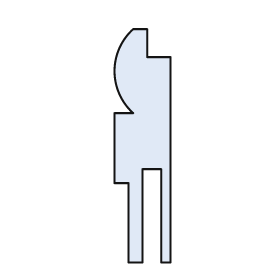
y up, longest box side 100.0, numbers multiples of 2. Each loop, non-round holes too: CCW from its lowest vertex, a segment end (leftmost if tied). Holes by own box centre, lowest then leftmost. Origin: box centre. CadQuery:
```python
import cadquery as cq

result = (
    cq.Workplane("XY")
    .moveTo(-6.0, -50.0)
    .lineTo(0.0, -50.0)
    .lineTo(0.0, -10.0)
    .lineTo(8.0, -10.0)
    .lineTo(8.0, -50.0)
    .lineTo(12.0, -50.0)
    .lineTo(12.0, 38.0)
    .lineTo(2.0, 38.0)
    .lineTo(2.0, 50.0)
    .lineTo(-4.0, 50.0)
    .threePointArc((-12.0, 32.0), (-4.0, 14.0))
    .lineTo(-12.0, 14.0)
    .lineTo(-12.0, -16.0)
    .lineTo(-6.0, -16.0)
    .close()
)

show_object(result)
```